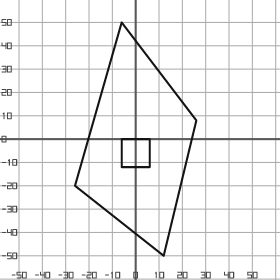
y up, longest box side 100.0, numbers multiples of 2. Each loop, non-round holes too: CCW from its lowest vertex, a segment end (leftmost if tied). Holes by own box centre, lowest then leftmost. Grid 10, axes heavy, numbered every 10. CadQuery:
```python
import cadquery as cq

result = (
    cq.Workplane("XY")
    .moveTo(12.0, -50.0)
    .lineTo(26.0, 8.0)
    .lineTo(-6.0, 50.0)
    .lineTo(-26.0, -20.0)
    .close()
    .moveTo(-6.0, -12.0)
    .lineTo(6.0, -12.0)
    .lineTo(6.0, 0.0)
    .lineTo(-6.0, 0.0)
    .close()
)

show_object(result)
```